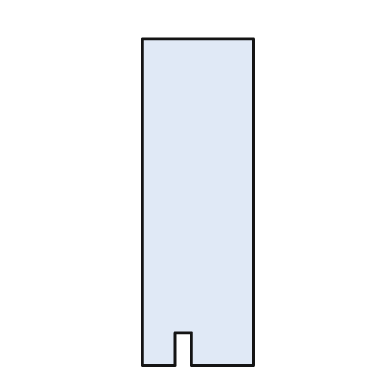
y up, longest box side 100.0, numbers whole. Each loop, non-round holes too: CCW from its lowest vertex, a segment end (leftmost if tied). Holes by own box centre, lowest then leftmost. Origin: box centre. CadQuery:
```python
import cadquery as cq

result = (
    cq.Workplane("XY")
    .moveTo(-17.0, -50.0)
    .lineTo(-7.0, -50.0)
    .lineTo(-7.0, -40.0)
    .lineTo(-2.0, -40.0)
    .lineTo(-2.0, -50.0)
    .lineTo(17.0, -50.0)
    .lineTo(17.0, 50.0)
    .lineTo(-17.0, 50.0)
    .close()
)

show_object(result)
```